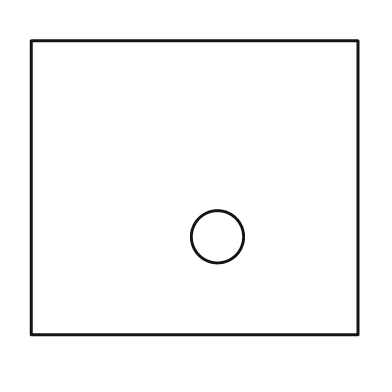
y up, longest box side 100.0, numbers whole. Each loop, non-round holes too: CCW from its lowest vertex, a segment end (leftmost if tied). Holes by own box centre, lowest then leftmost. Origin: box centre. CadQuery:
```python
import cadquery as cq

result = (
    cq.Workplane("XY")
    .moveTo(-50.0, -45.0)
    .lineTo(50.0, -45.0)
    .lineTo(50.0, 45.0)
    .lineTo(-50.0, 45.0)
    .close()
    .moveTo(7.0, -15.0)
    .circle(8.0)
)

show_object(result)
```